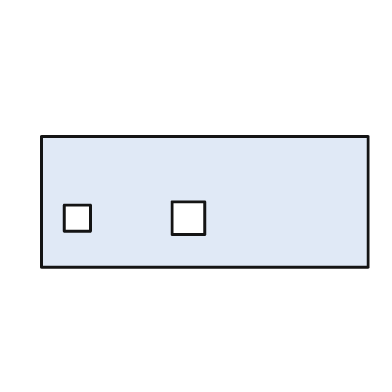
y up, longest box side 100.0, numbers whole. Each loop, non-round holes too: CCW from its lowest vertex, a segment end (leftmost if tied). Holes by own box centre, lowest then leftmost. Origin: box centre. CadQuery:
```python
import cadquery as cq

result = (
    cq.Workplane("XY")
    .moveTo(-50.0, -20.0)
    .lineTo(50.0, -20.0)
    .lineTo(50.0, 20.0)
    .lineTo(-50.0, 20.0)
    .close()
    .moveTo(-43.0, -9.0)
    .lineTo(-35.0, -9.0)
    .lineTo(-35.0, -1.0)
    .lineTo(-43.0, -1.0)
    .close()
    .moveTo(-10.0, -10.0)
    .lineTo(0.0, -10.0)
    .lineTo(0.0, 0.0)
    .lineTo(-10.0, 0.0)
    .close()
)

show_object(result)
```